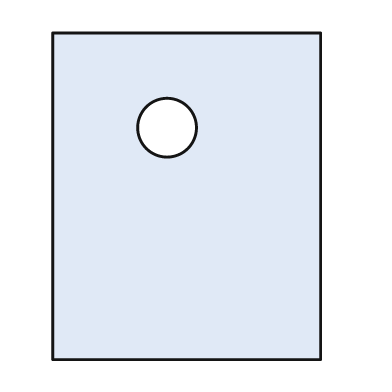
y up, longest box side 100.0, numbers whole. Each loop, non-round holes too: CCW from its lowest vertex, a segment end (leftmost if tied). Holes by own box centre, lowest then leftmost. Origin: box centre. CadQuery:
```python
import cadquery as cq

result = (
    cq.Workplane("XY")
    .moveTo(-41.0, -50.0)
    .lineTo(41.0, -50.0)
    .lineTo(41.0, 50.0)
    .lineTo(-41.0, 50.0)
    .close()
    .moveTo(-6.0, 21.0)
    .circle(9.0)
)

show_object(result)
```